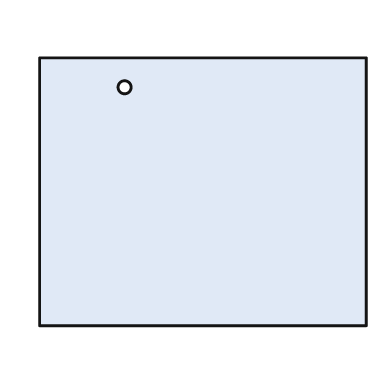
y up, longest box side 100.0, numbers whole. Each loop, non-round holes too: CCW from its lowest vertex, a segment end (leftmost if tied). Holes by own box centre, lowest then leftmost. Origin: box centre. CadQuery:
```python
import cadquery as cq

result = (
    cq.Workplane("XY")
    .moveTo(-50.0, -41.0)
    .lineTo(50.0, -41.0)
    .lineTo(50.0, 41.0)
    .lineTo(-50.0, 41.0)
    .close()
    .moveTo(-24.0, 32.0)
    .circle(2.0)
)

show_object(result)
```